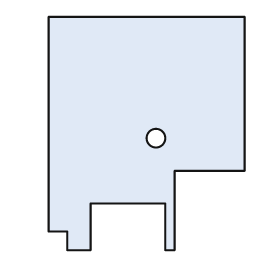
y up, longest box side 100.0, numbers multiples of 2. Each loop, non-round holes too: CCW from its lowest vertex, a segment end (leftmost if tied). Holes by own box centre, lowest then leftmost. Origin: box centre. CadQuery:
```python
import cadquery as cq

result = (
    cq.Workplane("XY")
    .moveTo(-34.0, -50.0)
    .lineTo(-24.0, -50.0)
    .lineTo(-24.0, -30.0)
    .lineTo(8.0, -30.0)
    .lineTo(8.0, -50.0)
    .lineTo(12.0, -50.0)
    .lineTo(12.0, -16.0)
    .lineTo(42.0, -16.0)
    .lineTo(42.0, 50.0)
    .lineTo(-42.0, 50.0)
    .lineTo(-42.0, -42.0)
    .lineTo(-34.0, -42.0)
    .close()
    .moveTo(4.0, -2.0)
    .circle(4.0)
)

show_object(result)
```